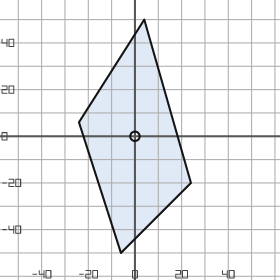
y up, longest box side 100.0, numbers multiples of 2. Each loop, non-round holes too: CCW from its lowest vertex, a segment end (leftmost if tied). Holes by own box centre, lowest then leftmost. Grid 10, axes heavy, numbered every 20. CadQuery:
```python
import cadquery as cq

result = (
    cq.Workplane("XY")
    .moveTo(-6.0, -50.0)
    .lineTo(24.0, -20.0)
    .lineTo(4.0, 50.0)
    .lineTo(-24.0, 6.0)
    .close()
    .moveTo(0.0, 0.0)
    .circle(2.0)
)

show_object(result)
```